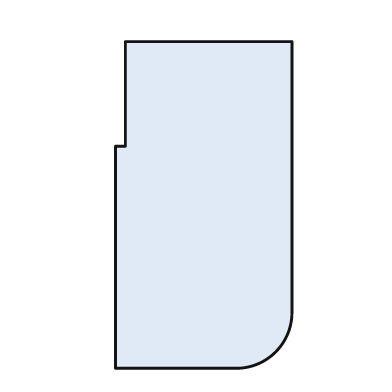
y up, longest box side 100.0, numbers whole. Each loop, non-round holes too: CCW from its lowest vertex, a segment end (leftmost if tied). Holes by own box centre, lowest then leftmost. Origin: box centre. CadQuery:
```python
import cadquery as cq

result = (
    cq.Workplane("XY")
    .moveTo(-27.0, -50.0)
    .lineTo(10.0, -50.0)
    .threePointArc((22.0, -45.0), (27.0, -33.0))
    .lineTo(27.0, 50.0)
    .lineTo(-24.0, 50.0)
    .lineTo(-24.0, 18.0)
    .lineTo(-27.0, 18.0)
    .close()
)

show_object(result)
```